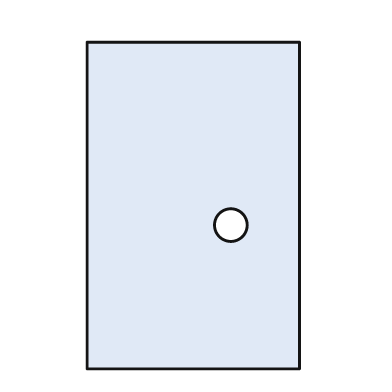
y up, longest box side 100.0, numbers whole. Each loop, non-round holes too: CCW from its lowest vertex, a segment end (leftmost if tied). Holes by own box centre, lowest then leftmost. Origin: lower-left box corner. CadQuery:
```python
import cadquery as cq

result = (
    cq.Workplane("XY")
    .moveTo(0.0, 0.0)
    .lineTo(65.0, 0.0)
    .lineTo(65.0, 100.0)
    .lineTo(0.0, 100.0)
    .close()
    .moveTo(44.0, 44.0)
    .circle(5.0)
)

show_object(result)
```